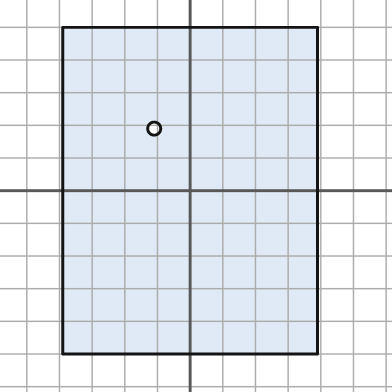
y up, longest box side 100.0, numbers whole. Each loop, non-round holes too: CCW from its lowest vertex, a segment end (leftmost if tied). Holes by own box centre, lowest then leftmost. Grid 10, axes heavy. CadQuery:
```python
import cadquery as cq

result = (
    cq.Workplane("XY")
    .moveTo(-39.0, -50.0)
    .lineTo(39.0, -50.0)
    .lineTo(39.0, 50.0)
    .lineTo(-39.0, 50.0)
    .close()
    .moveTo(-11.0, 19.0)
    .circle(2.0)
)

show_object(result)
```